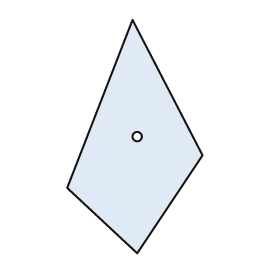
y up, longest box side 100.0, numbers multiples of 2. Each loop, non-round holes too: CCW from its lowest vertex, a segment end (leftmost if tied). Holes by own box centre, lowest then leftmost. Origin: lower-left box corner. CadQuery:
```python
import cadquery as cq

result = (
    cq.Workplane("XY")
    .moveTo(30.0, 0.0)
    .lineTo(58.0, 42.0)
    .lineTo(28.0, 100.0)
    .lineTo(0.0, 28.0)
    .close()
    .moveTo(30.0, 50.0)
    .circle(2.0)
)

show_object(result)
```